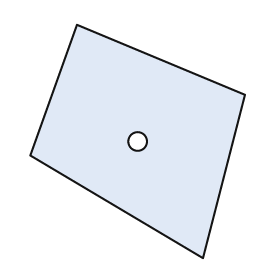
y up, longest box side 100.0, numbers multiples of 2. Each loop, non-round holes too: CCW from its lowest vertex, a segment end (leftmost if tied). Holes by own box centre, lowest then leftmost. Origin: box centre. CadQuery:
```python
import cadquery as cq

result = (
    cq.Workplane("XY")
    .moveTo(28.0, -50.0)
    .lineTo(46.0, 20.0)
    .lineTo(-26.0, 50.0)
    .lineTo(-46.0, -6.0)
    .close()
    .moveTo(0.0, 0.0)
    .circle(4.0)
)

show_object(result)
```